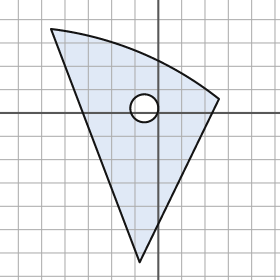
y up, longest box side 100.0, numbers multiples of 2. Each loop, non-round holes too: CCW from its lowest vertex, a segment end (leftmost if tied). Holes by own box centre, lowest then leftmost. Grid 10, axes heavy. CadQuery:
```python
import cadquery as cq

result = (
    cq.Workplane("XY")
    .moveTo(-8.0, -64.0)
    .lineTo(26.0, 6.0)
    .threePointArc((-8.0, 26.0), (-46.0, 36.0))
    .close()
    .moveTo(-6.0, 2.0)
    .circle(6.0)
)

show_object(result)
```